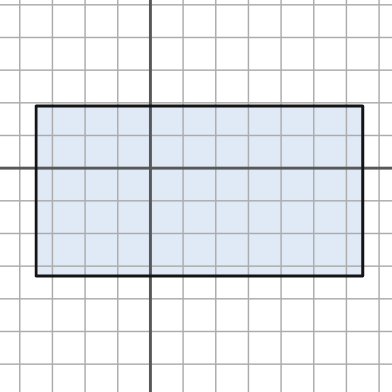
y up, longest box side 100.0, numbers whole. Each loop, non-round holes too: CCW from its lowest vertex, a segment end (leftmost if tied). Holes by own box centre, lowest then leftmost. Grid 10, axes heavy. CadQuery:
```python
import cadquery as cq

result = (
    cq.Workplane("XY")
    .moveTo(-35.0, -33.0)
    .lineTo(65.0, -33.0)
    .lineTo(65.0, 19.0)
    .lineTo(-35.0, 19.0)
    .close()
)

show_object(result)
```